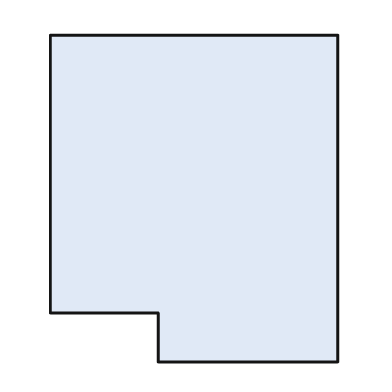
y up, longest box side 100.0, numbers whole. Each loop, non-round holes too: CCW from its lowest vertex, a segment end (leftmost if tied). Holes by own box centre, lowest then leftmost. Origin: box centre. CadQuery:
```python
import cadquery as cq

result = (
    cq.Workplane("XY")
    .moveTo(-11.0, -50.0)
    .lineTo(44.0, -50.0)
    .lineTo(44.0, 50.0)
    .lineTo(-44.0, 50.0)
    .lineTo(-44.0, -35.0)
    .lineTo(-11.0, -35.0)
    .close()
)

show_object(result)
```